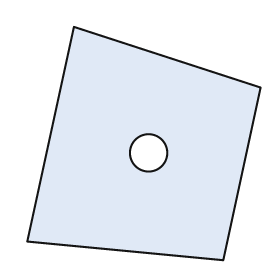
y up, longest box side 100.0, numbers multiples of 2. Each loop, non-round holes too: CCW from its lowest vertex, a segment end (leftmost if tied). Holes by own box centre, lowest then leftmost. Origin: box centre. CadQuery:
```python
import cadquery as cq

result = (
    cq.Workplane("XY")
    .moveTo(34.0, -50.0)
    .lineTo(50.0, 24.0)
    .lineTo(-30.0, 50.0)
    .lineTo(-50.0, -42.0)
    .close()
    .moveTo(2.0, -4.0)
    .circle(8.0)
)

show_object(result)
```